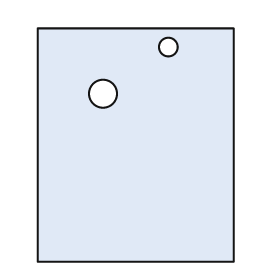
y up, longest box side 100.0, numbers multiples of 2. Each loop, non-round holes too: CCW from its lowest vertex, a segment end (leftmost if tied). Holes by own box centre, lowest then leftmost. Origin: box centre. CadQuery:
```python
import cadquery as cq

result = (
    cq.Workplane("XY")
    .moveTo(-42.0, -50.0)
    .lineTo(42.0, -50.0)
    .lineTo(42.0, 50.0)
    .lineTo(-42.0, 50.0)
    .close()
    .moveTo(-14.0, 22.0)
    .circle(6.0)
    .moveTo(14.0, 42.0)
    .circle(4.0)
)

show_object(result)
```